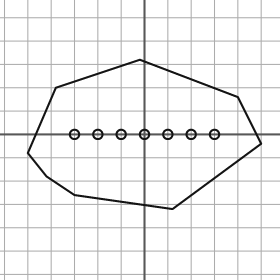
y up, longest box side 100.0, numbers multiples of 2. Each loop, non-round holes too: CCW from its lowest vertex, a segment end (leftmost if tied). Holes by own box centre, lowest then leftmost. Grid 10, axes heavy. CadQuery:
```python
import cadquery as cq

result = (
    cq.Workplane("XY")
    .moveTo(12.0, -32.0)
    .lineTo(50.0, -4.0)
    .lineTo(40.0, 16.0)
    .lineTo(-2.0, 32.0)
    .lineTo(-38.0, 20.0)
    .lineTo(-50.0, -8.0)
    .lineTo(-42.0, -18.0)
    .lineTo(-30.0, -26.0)
    .close()
    .moveTo(-30.0, 0.0)
    .circle(2.0)
    .moveTo(-20.0, 0.0)
    .circle(2.0)
    .moveTo(-10.0, 0.0)
    .circle(2.0)
    .moveTo(0.0, 0.0)
    .circle(2.0)
    .moveTo(10.0, 0.0)
    .circle(2.0)
    .moveTo(20.0, 0.0)
    .circle(2.0)
    .moveTo(30.0, 0.0)
    .circle(2.0)
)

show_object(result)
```